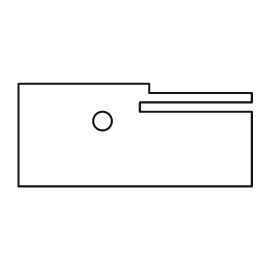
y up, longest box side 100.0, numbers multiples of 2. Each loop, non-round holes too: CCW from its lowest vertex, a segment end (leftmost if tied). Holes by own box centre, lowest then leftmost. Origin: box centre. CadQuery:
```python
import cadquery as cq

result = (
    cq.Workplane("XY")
    .moveTo(-50.0, -22.0)
    .lineTo(50.0, -22.0)
    .lineTo(50.0, 10.0)
    .lineTo(2.0, 10.0)
    .lineTo(2.0, 14.0)
    .lineTo(50.0, 14.0)
    .lineTo(50.0, 18.0)
    .lineTo(6.0, 18.0)
    .lineTo(6.0, 22.0)
    .lineTo(-50.0, 22.0)
    .close()
    .moveTo(-14.0, 6.0)
    .circle(4.0)
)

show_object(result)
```